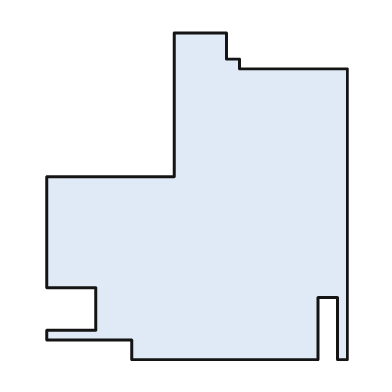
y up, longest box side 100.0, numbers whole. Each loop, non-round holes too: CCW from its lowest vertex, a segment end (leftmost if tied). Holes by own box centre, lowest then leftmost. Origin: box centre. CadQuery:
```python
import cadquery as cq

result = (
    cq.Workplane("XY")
    .moveTo(-20.0, -50.0)
    .lineTo(37.0, -50.0)
    .lineTo(37.0, -31.0)
    .lineTo(43.0, -31.0)
    .lineTo(43.0, -50.0)
    .lineTo(46.0, -50.0)
    .lineTo(46.0, 39.0)
    .lineTo(13.0, 39.0)
    .lineTo(13.0, 42.0)
    .lineTo(9.0, 42.0)
    .lineTo(9.0, 50.0)
    .lineTo(-7.0, 50.0)
    .lineTo(-7.0, 6.0)
    .lineTo(-46.0, 6.0)
    .lineTo(-46.0, -28.0)
    .lineTo(-31.0, -28.0)
    .lineTo(-31.0, -41.0)
    .lineTo(-46.0, -41.0)
    .lineTo(-46.0, -44.0)
    .lineTo(-20.0, -44.0)
    .close()
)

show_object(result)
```